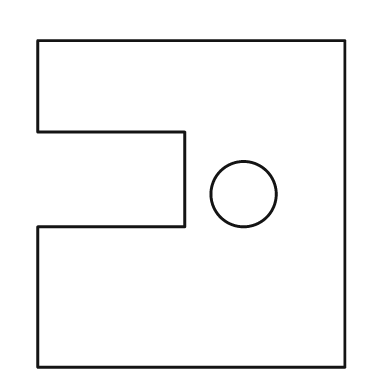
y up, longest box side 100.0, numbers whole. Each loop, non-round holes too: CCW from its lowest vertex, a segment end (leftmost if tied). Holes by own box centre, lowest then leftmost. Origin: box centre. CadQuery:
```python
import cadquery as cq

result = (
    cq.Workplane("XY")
    .moveTo(-47.0, -50.0)
    .lineTo(47.0, -50.0)
    .lineTo(47.0, 50.0)
    .lineTo(-47.0, 50.0)
    .lineTo(-47.0, 22.0)
    .lineTo(-2.0, 22.0)
    .lineTo(-2.0, -7.0)
    .lineTo(-47.0, -7.0)
    .close()
    .moveTo(16.0, 3.0)
    .circle(10.0)
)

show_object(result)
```